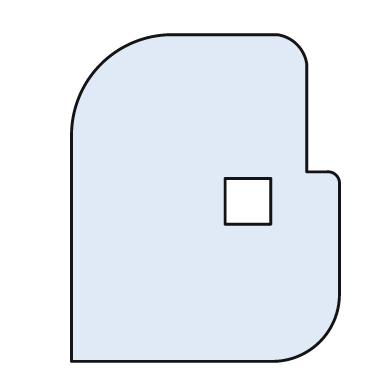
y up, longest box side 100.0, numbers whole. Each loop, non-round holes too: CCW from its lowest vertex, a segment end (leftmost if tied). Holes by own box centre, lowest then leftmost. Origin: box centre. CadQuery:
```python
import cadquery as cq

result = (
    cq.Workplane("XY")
    .moveTo(-41.0, -50.0)
    .lineTo(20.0, -50.0)
    .threePointArc((35.0, -44.0), (41.0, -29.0))
    .lineTo(41.0, 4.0)
    .threePointArc((40.0, 7.0), (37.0, 8.0))
    .lineTo(31.0, 8.0)
    .lineTo(31.0, 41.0)
    .threePointArc((28.0, 47.0), (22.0, 50.0))
    .lineTo(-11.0, 50.0)
    .threePointArc((-32.0, 41.0), (-41.0, 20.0))
    .close()
    .moveTo(6.0, -8.0)
    .lineTo(20.0, -8.0)
    .lineTo(20.0, 6.0)
    .lineTo(6.0, 6.0)
    .close()
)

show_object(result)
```